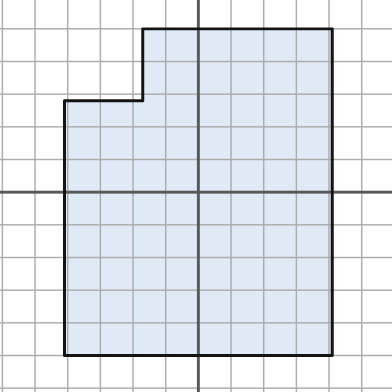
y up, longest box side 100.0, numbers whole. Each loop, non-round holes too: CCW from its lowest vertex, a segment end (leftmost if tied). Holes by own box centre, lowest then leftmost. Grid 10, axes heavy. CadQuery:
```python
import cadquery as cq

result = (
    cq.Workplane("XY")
    .moveTo(-41.0, -50.0)
    .lineTo(41.0, -50.0)
    .lineTo(41.0, 50.0)
    .lineTo(-17.0, 50.0)
    .lineTo(-17.0, 28.0)
    .lineTo(-41.0, 28.0)
    .close()
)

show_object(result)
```